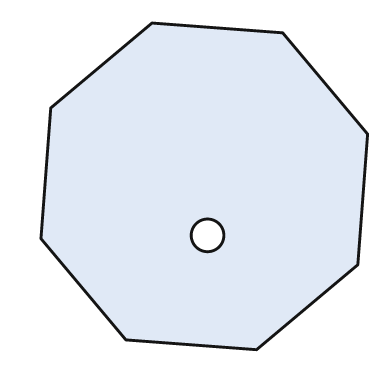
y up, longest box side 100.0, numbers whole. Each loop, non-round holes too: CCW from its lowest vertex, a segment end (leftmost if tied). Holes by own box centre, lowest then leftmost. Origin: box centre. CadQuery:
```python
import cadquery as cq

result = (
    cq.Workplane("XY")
    .moveTo(16.0, -50.0)
    .lineTo(47.0, -24.0)
    .lineTo(50.0, 16.0)
    .lineTo(24.0, 47.0)
    .lineTo(-16.0, 50.0)
    .lineTo(-47.0, 24.0)
    .lineTo(-50.0, -16.0)
    .lineTo(-24.0, -47.0)
    .close()
    .moveTo(1.0, -15.0)
    .circle(5.0)
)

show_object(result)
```